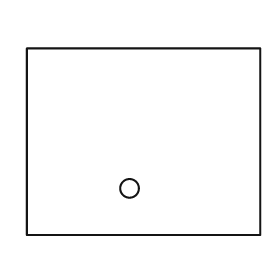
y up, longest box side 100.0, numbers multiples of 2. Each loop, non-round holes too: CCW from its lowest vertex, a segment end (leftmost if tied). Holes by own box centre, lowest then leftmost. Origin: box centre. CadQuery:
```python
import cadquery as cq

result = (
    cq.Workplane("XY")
    .moveTo(-50.0, -40.0)
    .lineTo(50.0, -40.0)
    .lineTo(50.0, 40.0)
    .lineTo(-50.0, 40.0)
    .close()
    .moveTo(-6.0, -20.0)
    .circle(4.0)
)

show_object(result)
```